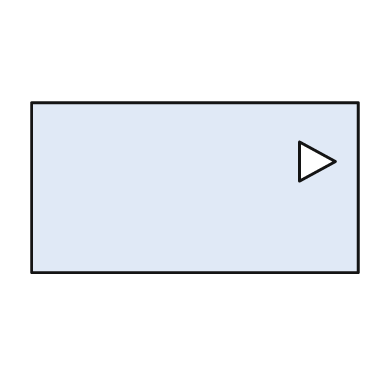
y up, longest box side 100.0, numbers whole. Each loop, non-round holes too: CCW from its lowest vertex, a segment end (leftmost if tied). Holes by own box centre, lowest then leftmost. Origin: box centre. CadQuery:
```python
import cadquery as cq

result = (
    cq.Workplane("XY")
    .moveTo(-50.0, -26.0)
    .lineTo(50.0, -26.0)
    .lineTo(50.0, 26.0)
    .lineTo(-50.0, 26.0)
    .close()
    .moveTo(32.0, 2.0)
    .lineTo(43.0, 8.0)
    .lineTo(32.0, 14.0)
    .close()
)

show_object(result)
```